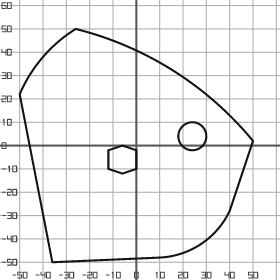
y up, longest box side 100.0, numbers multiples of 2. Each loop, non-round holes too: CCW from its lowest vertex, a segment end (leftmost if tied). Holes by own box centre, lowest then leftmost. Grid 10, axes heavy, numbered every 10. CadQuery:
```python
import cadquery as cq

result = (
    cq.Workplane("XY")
    .moveTo(-36.0, -50.0)
    .lineTo(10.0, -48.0)
    .threePointArc((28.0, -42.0), (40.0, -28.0))
    .lineTo(50.0, 2.0)
    .threePointArc((16.0, 32.0), (-26.0, 50.0))
    .threePointArc((-40.0, 38.0), (-50.0, 22.0))
    .close()
    .moveTo(-6.0, -12.0)
    .lineTo(0.0, -10.0)
    .lineTo(0.0, -2.0)
    .lineTo(-6.0, 0.0)
    .lineTo(-12.0, -2.0)
    .lineTo(-12.0, -10.0)
    .close()
    .moveTo(24.0, 4.0)
    .circle(6.0)
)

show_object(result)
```